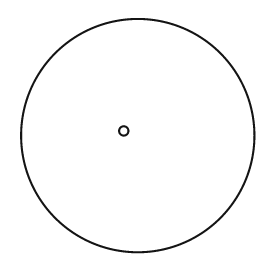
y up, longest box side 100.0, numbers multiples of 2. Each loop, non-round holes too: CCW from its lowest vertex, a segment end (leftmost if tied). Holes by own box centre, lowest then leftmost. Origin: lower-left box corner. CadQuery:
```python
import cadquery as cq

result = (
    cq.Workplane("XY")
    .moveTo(50.0, 50.0)
    .circle(50.0)
    .moveTo(44.0, 52.0)
    .circle(2.0)
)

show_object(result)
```